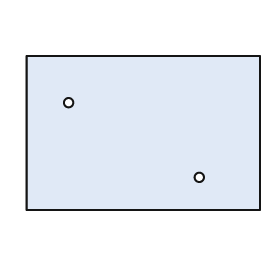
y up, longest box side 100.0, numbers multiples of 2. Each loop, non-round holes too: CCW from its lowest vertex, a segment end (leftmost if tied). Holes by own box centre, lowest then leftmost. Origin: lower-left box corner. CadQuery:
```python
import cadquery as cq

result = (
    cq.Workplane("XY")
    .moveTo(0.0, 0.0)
    .lineTo(100.0, 0.0)
    .lineTo(100.0, 66.0)
    .lineTo(0.0, 66.0)
    .close()
    .moveTo(74.0, 14.0)
    .circle(2.0)
    .moveTo(18.0, 46.0)
    .circle(2.0)
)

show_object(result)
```